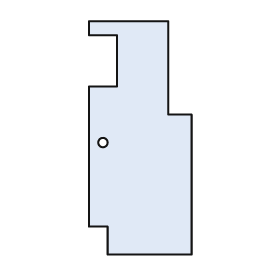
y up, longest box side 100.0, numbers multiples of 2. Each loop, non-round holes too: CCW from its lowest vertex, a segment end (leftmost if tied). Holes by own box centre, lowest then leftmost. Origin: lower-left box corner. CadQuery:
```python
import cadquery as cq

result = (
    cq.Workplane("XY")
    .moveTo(8.0, 0.0)
    .lineTo(44.0, 0.0)
    .lineTo(44.0, 60.0)
    .lineTo(34.0, 60.0)
    .lineTo(34.0, 100.0)
    .lineTo(0.0, 100.0)
    .lineTo(0.0, 94.0)
    .lineTo(12.0, 94.0)
    .lineTo(12.0, 72.0)
    .lineTo(0.0, 72.0)
    .lineTo(0.0, 12.0)
    .lineTo(8.0, 12.0)
    .close()
    .moveTo(6.0, 48.0)
    .circle(2.0)
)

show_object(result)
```